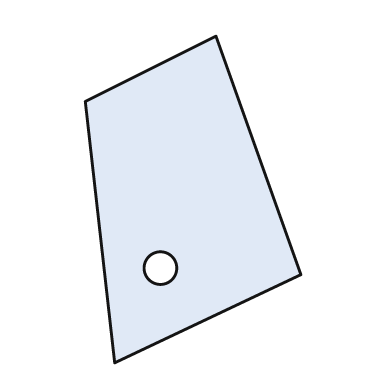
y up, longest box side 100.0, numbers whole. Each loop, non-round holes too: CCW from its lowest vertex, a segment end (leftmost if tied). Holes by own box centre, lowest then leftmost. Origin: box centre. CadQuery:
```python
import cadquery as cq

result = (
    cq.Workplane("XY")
    .moveTo(-24.0, -50.0)
    .lineTo(33.0, -23.0)
    .lineTo(7.0, 50.0)
    .lineTo(-33.0, 30.0)
    .close()
    .moveTo(-10.0, -21.0)
    .circle(5.0)
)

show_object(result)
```